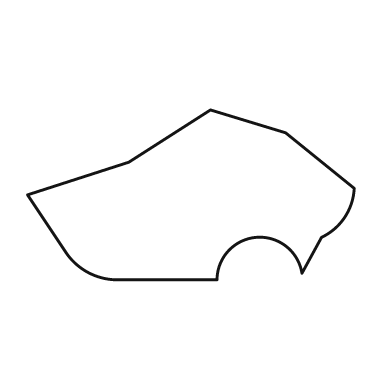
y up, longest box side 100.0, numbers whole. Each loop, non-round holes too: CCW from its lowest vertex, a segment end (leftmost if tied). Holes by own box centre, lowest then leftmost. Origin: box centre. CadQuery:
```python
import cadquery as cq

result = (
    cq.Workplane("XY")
    .moveTo(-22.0, -26.0)
    .lineTo(8.0, -26.0)
    .threePointArc((20.0, -13.0), (34.0, -24.0))
    .lineTo(40.0, -13.0)
    .threePointArc((47.0, -7.0), (50.0, 2.0))
    .lineTo(29.0, 19.0)
    .lineTo(6.0, 26.0)
    .lineTo(-19.0, 10.0)
    .lineTo(-50.0, 0.0)
    .lineTo(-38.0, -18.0)
    .threePointArc((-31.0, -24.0), (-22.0, -26.0))
    .close()
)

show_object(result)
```